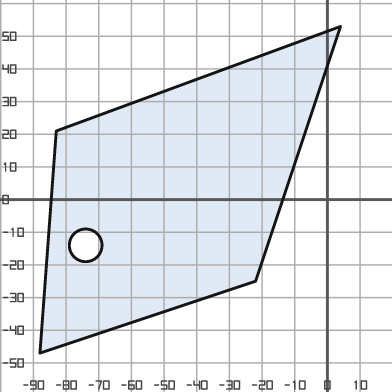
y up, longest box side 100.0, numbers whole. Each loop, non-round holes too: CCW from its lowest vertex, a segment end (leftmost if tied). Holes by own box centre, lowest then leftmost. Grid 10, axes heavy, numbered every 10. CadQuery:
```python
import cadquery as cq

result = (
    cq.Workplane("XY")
    .moveTo(-88.0, -47.0)
    .lineTo(-22.0, -25.0)
    .lineTo(4.0, 53.0)
    .lineTo(-83.0, 21.0)
    .close()
    .moveTo(-74.0, -14.0)
    .circle(5.0)
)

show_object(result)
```